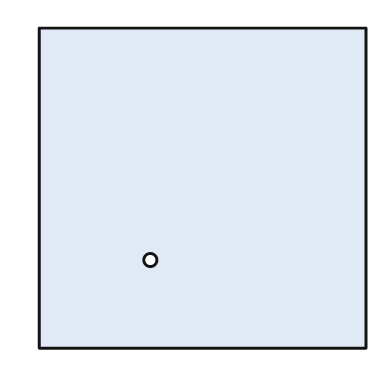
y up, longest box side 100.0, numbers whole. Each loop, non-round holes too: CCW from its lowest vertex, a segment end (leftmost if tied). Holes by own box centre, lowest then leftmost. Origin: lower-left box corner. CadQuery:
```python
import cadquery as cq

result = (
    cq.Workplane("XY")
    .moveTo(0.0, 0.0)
    .lineTo(100.0, 0.0)
    .lineTo(100.0, 98.0)
    .lineTo(0.0, 98.0)
    .close()
    .moveTo(34.0, 27.0)
    .circle(2.0)
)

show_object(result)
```